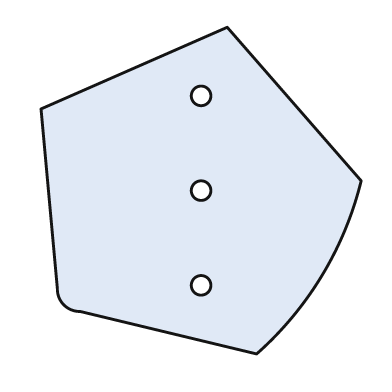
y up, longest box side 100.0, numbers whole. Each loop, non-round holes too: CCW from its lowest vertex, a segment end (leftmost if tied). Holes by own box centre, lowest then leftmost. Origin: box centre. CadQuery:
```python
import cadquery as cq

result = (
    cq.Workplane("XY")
    .moveTo(17.0, -50.0)
    .threePointArc((37.0, -26.0), (49.0, 3.0))
    .lineTo(8.0, 50.0)
    .lineTo(-49.0, 25.0)
    .lineTo(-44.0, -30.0)
    .threePointArc((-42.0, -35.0), (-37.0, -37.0))
    .close()
    .moveTo(0.0, -29.0)
    .circle(3.0)
    .moveTo(0.0, 0.0)
    .circle(3.0)
    .moveTo(0.0, 29.0)
    .circle(3.0)
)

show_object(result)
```